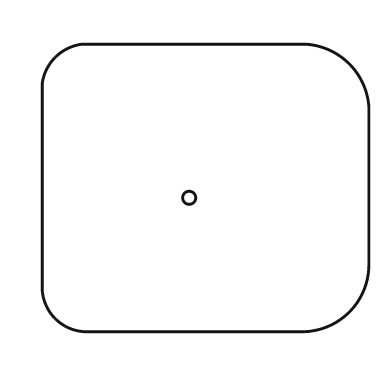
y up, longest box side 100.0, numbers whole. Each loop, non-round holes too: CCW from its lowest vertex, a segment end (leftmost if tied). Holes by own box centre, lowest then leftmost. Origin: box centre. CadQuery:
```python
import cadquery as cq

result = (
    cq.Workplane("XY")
    .moveTo(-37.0, -44.0)
    .lineTo(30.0, -44.0)
    .threePointArc((44.0, -38.0), (50.0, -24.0))
    .lineTo(50.0, 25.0)
    .threePointArc((44.0, 38.0), (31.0, 44.0))
    .lineTo(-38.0, 44.0)
    .threePointArc((-46.0, 40.0), (-50.0, 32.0))
    .lineTo(-50.0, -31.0)
    .threePointArc((-46.0, -40.0), (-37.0, -44.0))
    .close()
    .moveTo(-5.0, -3.0)
    .circle(2.0)
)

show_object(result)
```